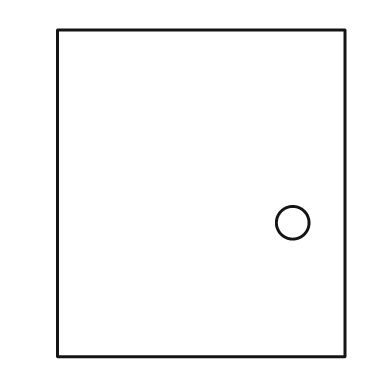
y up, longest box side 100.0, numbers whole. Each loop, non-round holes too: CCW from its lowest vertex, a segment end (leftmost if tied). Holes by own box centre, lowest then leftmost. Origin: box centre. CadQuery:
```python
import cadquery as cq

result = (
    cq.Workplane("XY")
    .moveTo(-44.0, -50.0)
    .lineTo(44.0, -50.0)
    .lineTo(44.0, 50.0)
    .lineTo(-44.0, 50.0)
    .close()
    .moveTo(28.0, -9.0)
    .circle(5.0)
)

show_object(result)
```